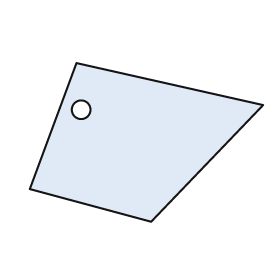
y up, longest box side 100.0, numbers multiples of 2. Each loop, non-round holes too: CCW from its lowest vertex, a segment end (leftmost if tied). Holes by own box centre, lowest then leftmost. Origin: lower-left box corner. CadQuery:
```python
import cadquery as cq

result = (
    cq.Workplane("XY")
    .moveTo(52.0, 0.0)
    .lineTo(100.0, 50.0)
    .lineTo(20.0, 68.0)
    .lineTo(0.0, 14.0)
    .close()
    .moveTo(22.0, 48.0)
    .circle(4.0)
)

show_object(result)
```